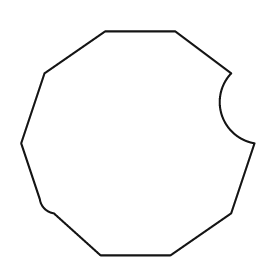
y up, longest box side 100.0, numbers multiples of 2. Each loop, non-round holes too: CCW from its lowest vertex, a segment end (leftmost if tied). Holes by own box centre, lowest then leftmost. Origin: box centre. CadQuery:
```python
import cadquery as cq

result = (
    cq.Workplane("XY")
    .moveTo(-16.0, -48.0)
    .lineTo(14.0, -48.0)
    .lineTo(40.0, -30.0)
    .lineTo(50.0, 0.0)
    .threePointArc((36.0, 12.0), (40.0, 30.0))
    .lineTo(16.0, 48.0)
    .lineTo(-14.0, 48.0)
    .lineTo(-40.0, 30.0)
    .lineTo(-50.0, 0.0)
    .lineTo(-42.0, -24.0)
    .threePointArc((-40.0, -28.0), (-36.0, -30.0))
    .close()
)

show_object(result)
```